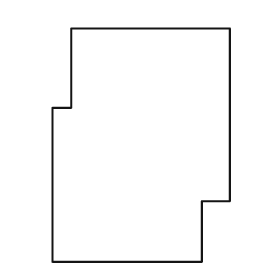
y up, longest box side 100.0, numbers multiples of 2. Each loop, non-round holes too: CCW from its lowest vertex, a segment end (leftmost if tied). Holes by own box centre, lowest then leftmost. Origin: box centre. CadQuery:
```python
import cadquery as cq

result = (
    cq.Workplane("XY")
    .moveTo(-38.0, -50.0)
    .lineTo(26.0, -50.0)
    .lineTo(26.0, -24.0)
    .lineTo(38.0, -24.0)
    .lineTo(38.0, 50.0)
    .lineTo(-30.0, 50.0)
    .lineTo(-30.0, 16.0)
    .lineTo(-38.0, 16.0)
    .close()
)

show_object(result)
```